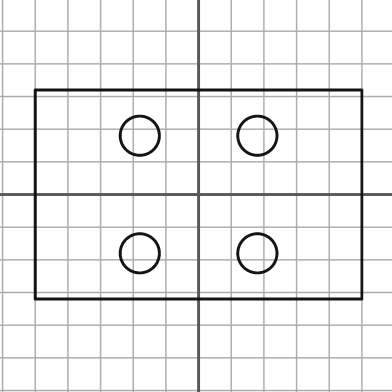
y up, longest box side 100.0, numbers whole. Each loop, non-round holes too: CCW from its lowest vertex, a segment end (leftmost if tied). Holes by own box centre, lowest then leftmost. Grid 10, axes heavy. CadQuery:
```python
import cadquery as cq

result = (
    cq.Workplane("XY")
    .moveTo(-50.0, -32.0)
    .lineTo(50.0, -32.0)
    .lineTo(50.0, 32.0)
    .lineTo(-50.0, 32.0)
    .close()
    .moveTo(-18.0, -18.0)
    .circle(6.0)
    .moveTo(18.0, -18.0)
    .circle(6.0)
    .moveTo(-18.0, 18.0)
    .circle(6.0)
    .moveTo(18.0, 18.0)
    .circle(6.0)
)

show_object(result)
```